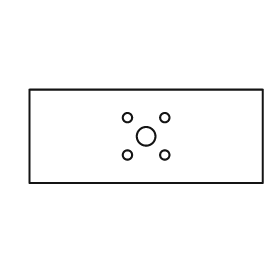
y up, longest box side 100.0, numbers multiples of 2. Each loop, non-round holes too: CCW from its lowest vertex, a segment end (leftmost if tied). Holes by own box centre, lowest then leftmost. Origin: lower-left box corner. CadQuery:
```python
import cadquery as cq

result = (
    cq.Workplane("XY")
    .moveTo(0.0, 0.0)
    .lineTo(100.0, 0.0)
    .lineTo(100.0, 40.0)
    .lineTo(0.0, 40.0)
    .close()
    .moveTo(42.0, 12.0)
    .circle(2.0)
    .moveTo(58.0, 12.0)
    .circle(2.0)
    .moveTo(50.0, 20.0)
    .circle(4.0)
    .moveTo(42.0, 28.0)
    .circle(2.0)
    .moveTo(58.0, 28.0)
    .circle(2.0)
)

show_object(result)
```